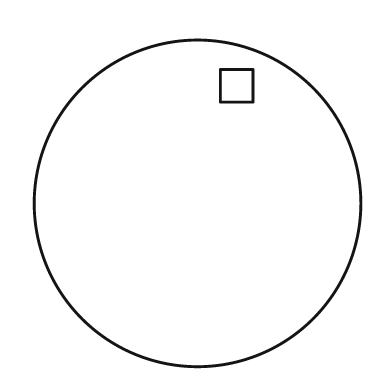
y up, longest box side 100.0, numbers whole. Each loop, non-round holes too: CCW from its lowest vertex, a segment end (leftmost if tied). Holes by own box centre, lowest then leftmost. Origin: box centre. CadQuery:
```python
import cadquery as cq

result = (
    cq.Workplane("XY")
    .moveTo(0.0, 0.0)
    .circle(50.0)
    .moveTo(7.0, 31.0)
    .lineTo(17.0, 31.0)
    .lineTo(17.0, 41.0)
    .lineTo(7.0, 41.0)
    .close()
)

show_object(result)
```